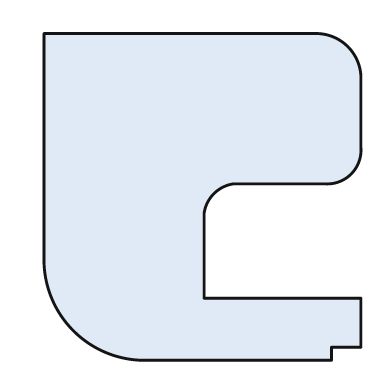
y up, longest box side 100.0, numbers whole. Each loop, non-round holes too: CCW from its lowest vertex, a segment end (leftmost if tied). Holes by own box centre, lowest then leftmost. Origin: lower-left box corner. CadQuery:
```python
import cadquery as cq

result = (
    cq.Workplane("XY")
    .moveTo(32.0, 0.0)
    .lineTo(88.0, 0.0)
    .lineTo(88.0, 4.0)
    .lineTo(97.0, 4.0)
    .lineTo(97.0, 19.0)
    .lineTo(49.0, 19.0)
    .lineTo(49.0, 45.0)
    .threePointArc((52.0, 51.0), (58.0, 54.0))
    .lineTo(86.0, 54.0)
    .threePointArc((94.0, 57.0), (97.0, 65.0))
    .lineTo(97.0, 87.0)
    .threePointArc((93.0, 96.0), (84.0, 100.0))
    .lineTo(0.0, 100.0)
    .lineTo(0.0, 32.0)
    .threePointArc((9.0, 9.0), (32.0, 0.0))
    .close()
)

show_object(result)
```